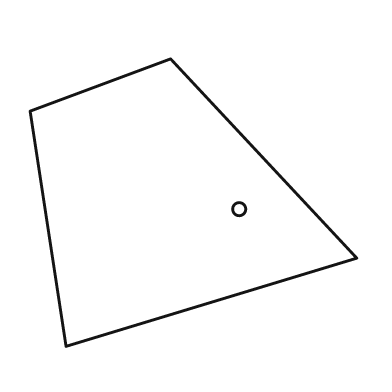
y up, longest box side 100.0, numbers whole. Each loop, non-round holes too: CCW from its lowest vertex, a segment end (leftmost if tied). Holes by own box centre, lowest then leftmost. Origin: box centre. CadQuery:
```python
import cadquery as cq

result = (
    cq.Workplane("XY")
    .moveTo(-39.0, -44.0)
    .lineTo(50.0, -17.0)
    .lineTo(-7.0, 44.0)
    .lineTo(-50.0, 28.0)
    .close()
    .moveTo(14.0, -2.0)
    .circle(2.0)
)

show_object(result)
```